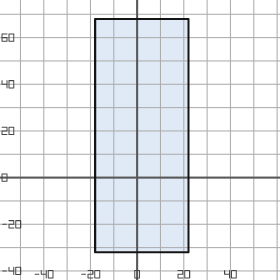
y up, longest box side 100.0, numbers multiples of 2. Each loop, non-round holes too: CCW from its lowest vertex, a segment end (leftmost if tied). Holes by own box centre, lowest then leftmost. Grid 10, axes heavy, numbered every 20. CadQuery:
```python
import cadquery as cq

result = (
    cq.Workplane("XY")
    .moveTo(-18.0, -32.0)
    .lineTo(22.0, -32.0)
    .lineTo(22.0, 68.0)
    .lineTo(-18.0, 68.0)
    .close()
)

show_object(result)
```